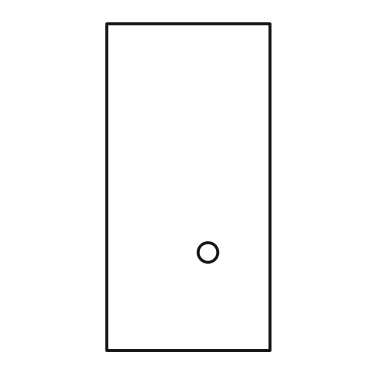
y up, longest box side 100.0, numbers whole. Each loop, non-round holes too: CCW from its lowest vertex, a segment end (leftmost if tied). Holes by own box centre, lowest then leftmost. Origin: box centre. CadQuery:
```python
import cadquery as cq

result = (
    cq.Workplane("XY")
    .moveTo(-25.0, -50.0)
    .lineTo(25.0, -50.0)
    .lineTo(25.0, 50.0)
    .lineTo(-25.0, 50.0)
    .close()
    .moveTo(6.0, -20.0)
    .circle(3.0)
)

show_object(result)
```